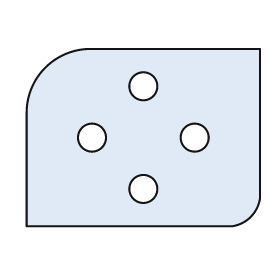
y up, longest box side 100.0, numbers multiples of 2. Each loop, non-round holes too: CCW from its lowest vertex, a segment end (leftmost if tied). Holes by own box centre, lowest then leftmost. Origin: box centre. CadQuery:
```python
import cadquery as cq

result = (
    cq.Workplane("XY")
    .moveTo(-50.0, -38.0)
    .lineTo(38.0, -38.0)
    .threePointArc((46.0, -34.0), (50.0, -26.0))
    .lineTo(50.0, 38.0)
    .lineTo(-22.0, 38.0)
    .threePointArc((-42.0, 30.0), (-50.0, 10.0))
    .close()
    .moveTo(0.0, -22.0)
    .circle(6.0)
    .moveTo(-22.0, 0.0)
    .circle(6.0)
    .moveTo(22.0, 0.0)
    .circle(6.0)
    .moveTo(0.0, 22.0)
    .circle(6.0)
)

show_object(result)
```